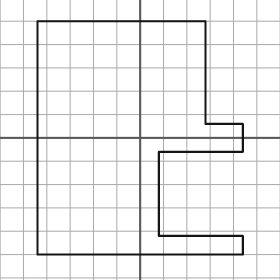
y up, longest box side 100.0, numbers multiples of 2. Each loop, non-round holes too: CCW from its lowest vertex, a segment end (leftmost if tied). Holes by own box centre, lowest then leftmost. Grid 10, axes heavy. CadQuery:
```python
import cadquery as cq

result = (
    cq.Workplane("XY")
    .moveTo(-44.0, -50.0)
    .lineTo(44.0, -50.0)
    .lineTo(44.0, -42.0)
    .lineTo(8.0, -42.0)
    .lineTo(8.0, -6.0)
    .lineTo(44.0, -6.0)
    .lineTo(44.0, 6.0)
    .lineTo(28.0, 6.0)
    .lineTo(28.0, 50.0)
    .lineTo(-44.0, 50.0)
    .close()
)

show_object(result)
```